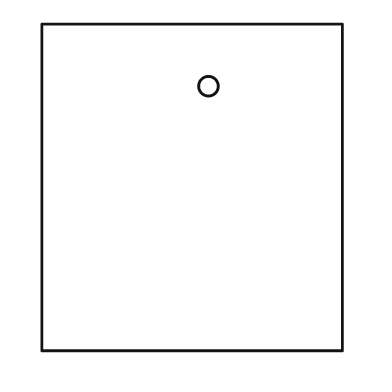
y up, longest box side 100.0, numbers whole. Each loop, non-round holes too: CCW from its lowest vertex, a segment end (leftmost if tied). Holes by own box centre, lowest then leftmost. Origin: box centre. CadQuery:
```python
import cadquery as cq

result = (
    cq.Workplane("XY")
    .moveTo(-46.0, -50.0)
    .lineTo(46.0, -50.0)
    .lineTo(46.0, 50.0)
    .lineTo(-46.0, 50.0)
    .close()
    .moveTo(5.0, 31.0)
    .circle(3.0)
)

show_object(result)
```